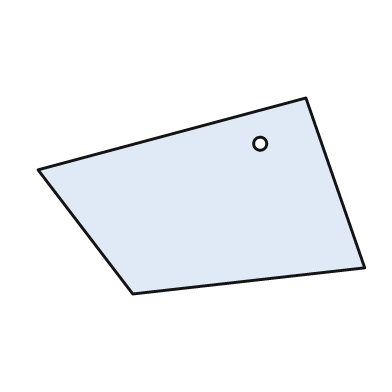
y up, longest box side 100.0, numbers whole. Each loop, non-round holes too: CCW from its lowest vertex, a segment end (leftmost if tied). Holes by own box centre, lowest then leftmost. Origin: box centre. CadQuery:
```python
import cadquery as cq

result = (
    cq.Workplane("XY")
    .moveTo(-21.0, -30.0)
    .lineTo(50.0, -22.0)
    .lineTo(32.0, 30.0)
    .lineTo(-50.0, 8.0)
    .close()
    .moveTo(18.0, 16.0)
    .circle(2.0)
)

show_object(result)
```